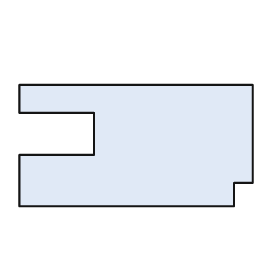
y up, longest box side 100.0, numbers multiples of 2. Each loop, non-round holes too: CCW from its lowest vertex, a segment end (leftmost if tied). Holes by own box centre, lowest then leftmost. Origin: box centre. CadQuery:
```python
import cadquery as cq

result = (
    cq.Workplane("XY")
    .moveTo(-50.0, -26.0)
    .lineTo(42.0, -26.0)
    .lineTo(42.0, -16.0)
    .lineTo(50.0, -16.0)
    .lineTo(50.0, 26.0)
    .lineTo(-50.0, 26.0)
    .lineTo(-50.0, 14.0)
    .lineTo(-18.0, 14.0)
    .lineTo(-18.0, -4.0)
    .lineTo(-50.0, -4.0)
    .close()
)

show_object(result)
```